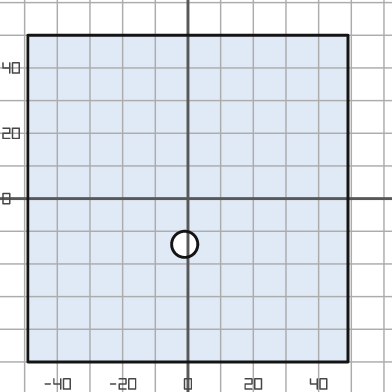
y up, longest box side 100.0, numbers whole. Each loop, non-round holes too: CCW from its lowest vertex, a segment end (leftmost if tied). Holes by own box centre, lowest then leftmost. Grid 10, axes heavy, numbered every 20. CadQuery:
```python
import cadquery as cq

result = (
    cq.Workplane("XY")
    .moveTo(-49.0, -50.0)
    .lineTo(49.0, -50.0)
    .lineTo(49.0, 50.0)
    .lineTo(-49.0, 50.0)
    .close()
    .moveTo(-1.0, -14.0)
    .circle(4.0)
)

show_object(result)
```